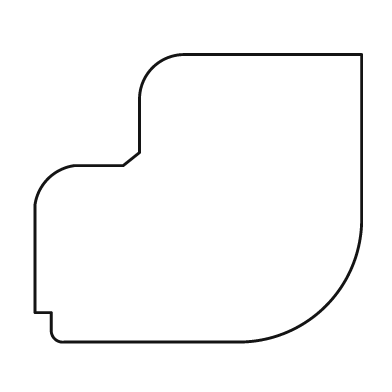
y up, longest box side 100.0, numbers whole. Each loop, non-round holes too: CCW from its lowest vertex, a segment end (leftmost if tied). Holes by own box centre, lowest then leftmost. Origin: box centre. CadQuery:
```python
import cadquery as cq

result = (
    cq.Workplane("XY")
    .moveTo(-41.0, -44.0)
    .lineTo(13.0, -44.0)
    .threePointArc((39.0, -33.0), (50.0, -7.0))
    .lineTo(50.0, 44.0)
    .lineTo(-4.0, 44.0)
    .threePointArc((-14.0, 40.0), (-18.0, 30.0))
    .lineTo(-18.0, 14.0)
    .lineTo(-23.0, 10.0)
    .lineTo(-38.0, 10.0)
    .threePointArc((-46.0, 6.0), (-50.0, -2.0))
    .lineTo(-50.0, -35.0)
    .lineTo(-45.0, -35.0)
    .lineTo(-45.0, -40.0)
    .threePointArc((-44.0, -43.0), (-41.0, -44.0))
    .close()
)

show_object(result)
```